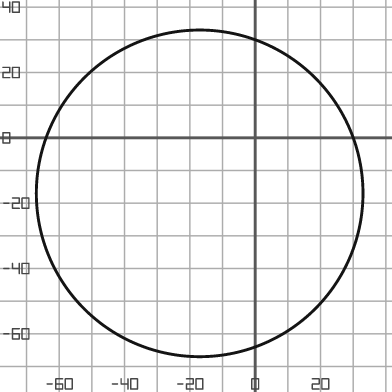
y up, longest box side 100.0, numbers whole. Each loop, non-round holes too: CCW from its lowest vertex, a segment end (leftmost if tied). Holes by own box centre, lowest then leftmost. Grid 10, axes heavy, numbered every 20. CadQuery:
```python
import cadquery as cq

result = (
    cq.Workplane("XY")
    .moveTo(-17.0, -17.0)
    .circle(50.0)
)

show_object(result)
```